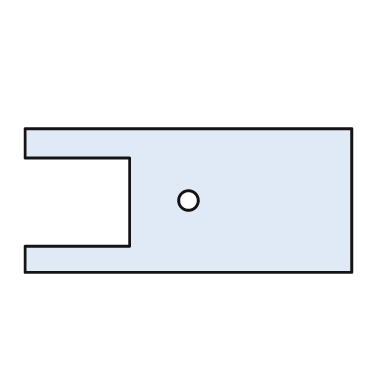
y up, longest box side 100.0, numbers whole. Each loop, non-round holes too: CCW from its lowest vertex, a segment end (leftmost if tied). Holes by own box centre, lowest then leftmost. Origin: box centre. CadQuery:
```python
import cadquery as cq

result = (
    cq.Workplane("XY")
    .moveTo(-50.0, -22.0)
    .lineTo(50.0, -22.0)
    .lineTo(50.0, 22.0)
    .lineTo(-50.0, 22.0)
    .lineTo(-50.0, 13.0)
    .lineTo(-18.0, 13.0)
    .lineTo(-18.0, -14.0)
    .lineTo(-50.0, -14.0)
    .close()
    .moveTo(0.0, 0.0)
    .circle(3.0)
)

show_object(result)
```